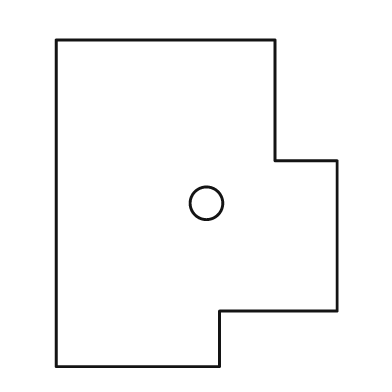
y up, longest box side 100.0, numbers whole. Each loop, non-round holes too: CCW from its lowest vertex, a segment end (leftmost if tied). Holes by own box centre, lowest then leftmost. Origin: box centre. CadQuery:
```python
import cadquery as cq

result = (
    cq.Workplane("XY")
    .moveTo(-43.0, -50.0)
    .lineTo(7.0, -50.0)
    .lineTo(7.0, -33.0)
    .lineTo(43.0, -33.0)
    .lineTo(43.0, 13.0)
    .lineTo(24.0, 13.0)
    .lineTo(24.0, 50.0)
    .lineTo(-43.0, 50.0)
    .close()
    .moveTo(3.0, 0.0)
    .circle(5.0)
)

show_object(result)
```